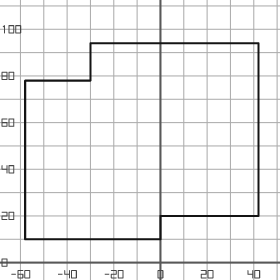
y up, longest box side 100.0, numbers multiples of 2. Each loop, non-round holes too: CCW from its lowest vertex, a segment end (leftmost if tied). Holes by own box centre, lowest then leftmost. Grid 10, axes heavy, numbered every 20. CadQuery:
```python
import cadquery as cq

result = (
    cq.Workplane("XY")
    .moveTo(-58.0, 10.0)
    .lineTo(0.0, 10.0)
    .lineTo(0.0, 20.0)
    .lineTo(42.0, 20.0)
    .lineTo(42.0, 94.0)
    .lineTo(-30.0, 94.0)
    .lineTo(-30.0, 78.0)
    .lineTo(-58.0, 78.0)
    .close()
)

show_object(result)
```